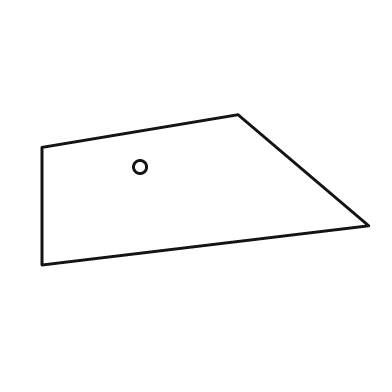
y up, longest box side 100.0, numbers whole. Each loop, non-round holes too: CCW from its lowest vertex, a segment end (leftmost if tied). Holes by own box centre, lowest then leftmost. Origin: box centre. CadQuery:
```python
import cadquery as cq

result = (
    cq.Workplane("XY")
    .moveTo(-50.0, -23.0)
    .lineTo(50.0, -11.0)
    .lineTo(10.0, 23.0)
    .lineTo(-50.0, 13.0)
    .close()
    .moveTo(-20.0, 7.0)
    .circle(2.0)
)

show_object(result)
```